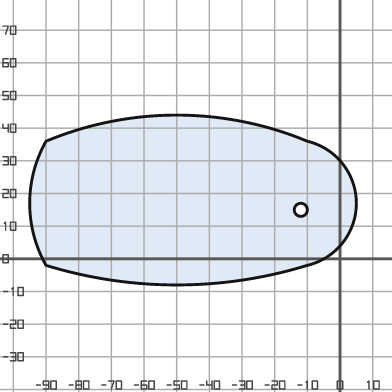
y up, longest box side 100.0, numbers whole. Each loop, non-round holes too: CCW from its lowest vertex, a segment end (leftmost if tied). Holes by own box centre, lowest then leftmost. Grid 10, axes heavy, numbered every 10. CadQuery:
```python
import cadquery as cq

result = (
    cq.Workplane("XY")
    .moveTo(-90.0, -2.0)
    .threePointArc((-50.0, -8.0), (-10.0, -2.0))
    .threePointArc((5.0, 17.0), (-10.0, 36.0))
    .threePointArc((-50.0, 44.0), (-90.0, 36.0))
    .threePointArc((-95.0, 17.0), (-90.0, -2.0))
    .close()
    .moveTo(-12.0, 15.0)
    .circle(2.0)
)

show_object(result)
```